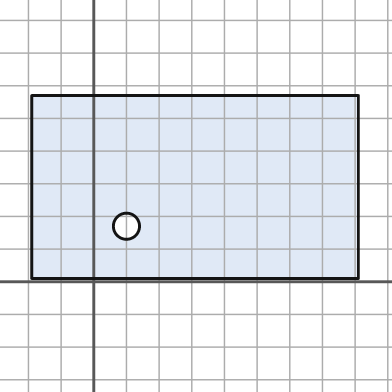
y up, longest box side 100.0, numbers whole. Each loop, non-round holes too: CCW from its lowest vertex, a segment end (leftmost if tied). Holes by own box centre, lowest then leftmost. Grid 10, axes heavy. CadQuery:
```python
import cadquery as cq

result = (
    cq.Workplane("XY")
    .moveTo(-19.0, 1.0)
    .lineTo(81.0, 1.0)
    .lineTo(81.0, 57.0)
    .lineTo(-19.0, 57.0)
    .close()
    .moveTo(10.0, 17.0)
    .circle(4.0)
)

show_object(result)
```